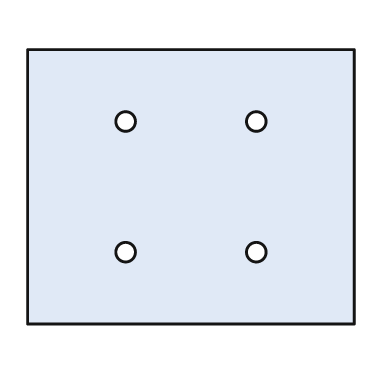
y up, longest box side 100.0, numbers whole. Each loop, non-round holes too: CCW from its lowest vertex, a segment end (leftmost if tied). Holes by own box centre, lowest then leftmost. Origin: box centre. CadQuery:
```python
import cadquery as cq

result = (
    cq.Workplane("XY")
    .moveTo(-50.0, -42.0)
    .lineTo(50.0, -42.0)
    .lineTo(50.0, 42.0)
    .lineTo(-50.0, 42.0)
    .close()
    .moveTo(-20.0, -20.0)
    .circle(3.0)
    .moveTo(20.0, -20.0)
    .circle(3.0)
    .moveTo(-20.0, 20.0)
    .circle(3.0)
    .moveTo(20.0, 20.0)
    .circle(3.0)
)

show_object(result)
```